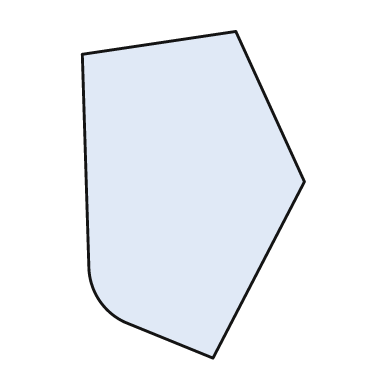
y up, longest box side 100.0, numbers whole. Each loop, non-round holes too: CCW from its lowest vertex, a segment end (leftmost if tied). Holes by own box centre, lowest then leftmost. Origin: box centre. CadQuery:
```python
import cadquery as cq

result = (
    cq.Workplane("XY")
    .moveTo(6.0, -50.0)
    .lineTo(34.0, 4.0)
    .lineTo(13.0, 50.0)
    .lineTo(-34.0, 43.0)
    .lineTo(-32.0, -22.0)
    .threePointArc((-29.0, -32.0), (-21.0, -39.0))
    .close()
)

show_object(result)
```